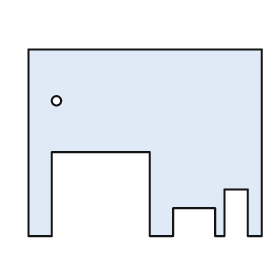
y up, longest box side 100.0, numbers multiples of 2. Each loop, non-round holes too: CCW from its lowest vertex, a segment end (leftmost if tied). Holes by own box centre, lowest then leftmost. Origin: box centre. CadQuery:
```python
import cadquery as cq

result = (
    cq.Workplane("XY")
    .moveTo(-50.0, -40.0)
    .lineTo(-40.0, -40.0)
    .lineTo(-40.0, -4.0)
    .lineTo(2.0, -4.0)
    .lineTo(2.0, -40.0)
    .lineTo(12.0, -40.0)
    .lineTo(12.0, -28.0)
    .lineTo(30.0, -28.0)
    .lineTo(30.0, -40.0)
    .lineTo(34.0, -40.0)
    .lineTo(34.0, -20.0)
    .lineTo(44.0, -20.0)
    .lineTo(44.0, -40.0)
    .lineTo(50.0, -40.0)
    .lineTo(50.0, 40.0)
    .lineTo(-50.0, 40.0)
    .close()
    .moveTo(-38.0, 18.0)
    .circle(2.0)
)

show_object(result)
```